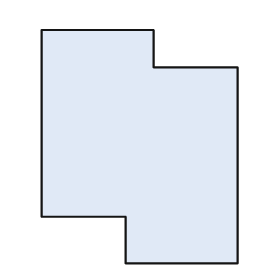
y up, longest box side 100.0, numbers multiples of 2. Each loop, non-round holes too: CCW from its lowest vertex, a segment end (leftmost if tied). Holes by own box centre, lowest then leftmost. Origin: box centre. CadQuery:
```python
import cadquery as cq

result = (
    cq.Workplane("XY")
    .moveTo(-6.0, -50.0)
    .lineTo(42.0, -50.0)
    .lineTo(42.0, 34.0)
    .lineTo(6.0, 34.0)
    .lineTo(6.0, 50.0)
    .lineTo(-42.0, 50.0)
    .lineTo(-42.0, -30.0)
    .lineTo(-6.0, -30.0)
    .close()
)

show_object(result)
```